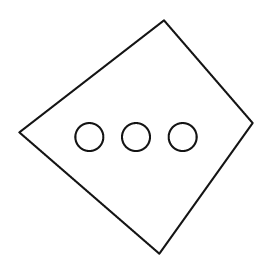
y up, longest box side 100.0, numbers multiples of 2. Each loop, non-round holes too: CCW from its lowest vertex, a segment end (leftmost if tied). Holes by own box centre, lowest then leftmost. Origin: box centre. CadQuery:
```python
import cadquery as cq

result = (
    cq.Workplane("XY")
    .moveTo(10.0, -50.0)
    .lineTo(50.0, 6.0)
    .lineTo(12.0, 50.0)
    .lineTo(-50.0, 2.0)
    .close()
    .moveTo(-20.0, 0.0)
    .circle(6.0)
    .moveTo(0.0, 0.0)
    .circle(6.0)
    .moveTo(20.0, 0.0)
    .circle(6.0)
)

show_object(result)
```